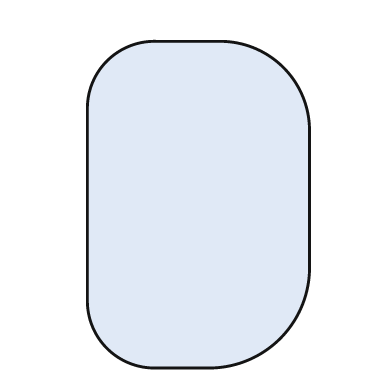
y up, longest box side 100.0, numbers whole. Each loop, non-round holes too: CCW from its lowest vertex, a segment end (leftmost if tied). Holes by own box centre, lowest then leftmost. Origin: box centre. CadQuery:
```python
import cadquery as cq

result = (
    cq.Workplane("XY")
    .moveTo(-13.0, -50.0)
    .lineTo(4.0, -50.0)
    .threePointArc((25.0, -41.0), (34.0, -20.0))
    .lineTo(34.0, 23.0)
    .threePointArc((26.0, 42.0), (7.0, 50.0))
    .lineTo(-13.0, 50.0)
    .threePointArc((-28.0, 44.0), (-34.0, 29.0))
    .lineTo(-34.0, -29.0)
    .threePointArc((-28.0, -44.0), (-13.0, -50.0))
    .close()
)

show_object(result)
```